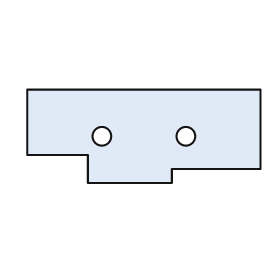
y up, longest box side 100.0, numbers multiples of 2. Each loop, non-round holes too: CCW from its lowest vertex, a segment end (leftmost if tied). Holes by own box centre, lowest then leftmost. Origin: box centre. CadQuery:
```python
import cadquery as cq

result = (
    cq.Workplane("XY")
    .moveTo(-24.0, -20.0)
    .lineTo(12.0, -20.0)
    .lineTo(12.0, -14.0)
    .lineTo(50.0, -14.0)
    .lineTo(50.0, 20.0)
    .lineTo(-50.0, 20.0)
    .lineTo(-50.0, -8.0)
    .lineTo(-24.0, -8.0)
    .close()
    .moveTo(-18.0, 0.0)
    .circle(4.0)
    .moveTo(18.0, 0.0)
    .circle(4.0)
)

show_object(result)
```